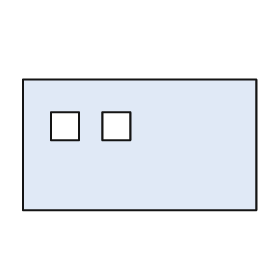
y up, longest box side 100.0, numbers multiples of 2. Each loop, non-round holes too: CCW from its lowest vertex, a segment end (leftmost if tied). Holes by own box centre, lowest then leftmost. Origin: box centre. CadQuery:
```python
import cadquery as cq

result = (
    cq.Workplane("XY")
    .moveTo(-50.0, -28.0)
    .lineTo(50.0, -28.0)
    .lineTo(50.0, 28.0)
    .lineTo(-50.0, 28.0)
    .close()
    .moveTo(-38.0, 2.0)
    .lineTo(-26.0, 2.0)
    .lineTo(-26.0, 14.0)
    .lineTo(-38.0, 14.0)
    .close()
    .moveTo(-16.0, 2.0)
    .lineTo(-4.0, 2.0)
    .lineTo(-4.0, 14.0)
    .lineTo(-16.0, 14.0)
    .close()
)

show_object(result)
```